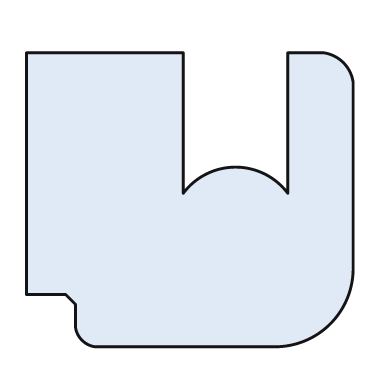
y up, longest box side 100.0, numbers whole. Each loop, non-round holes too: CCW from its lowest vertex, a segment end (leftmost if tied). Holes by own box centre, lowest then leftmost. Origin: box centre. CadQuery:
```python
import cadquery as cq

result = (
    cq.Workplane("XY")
    .moveTo(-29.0, -45.0)
    .lineTo(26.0, -45.0)
    .threePointArc((43.0, -38.0), (50.0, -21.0))
    .lineTo(50.0, 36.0)
    .threePointArc((47.0, 42.0), (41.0, 45.0))
    .lineTo(30.0, 45.0)
    .lineTo(30.0, 2.0)
    .threePointArc((14.0, 10.0), (-2.0, 2.0))
    .lineTo(-2.0, 45.0)
    .lineTo(-50.0, 45.0)
    .lineTo(-50.0, -29.0)
    .lineTo(-38.0, -29.0)
    .lineTo(-35.0, -32.0)
    .lineTo(-35.0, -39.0)
    .threePointArc((-33.0, -43.0), (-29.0, -45.0))
    .close()
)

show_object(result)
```